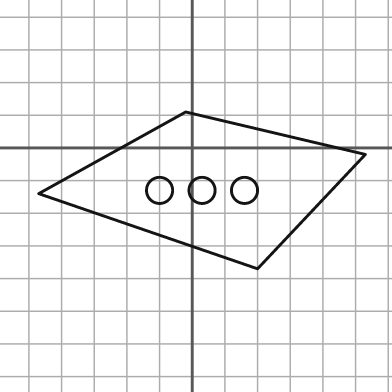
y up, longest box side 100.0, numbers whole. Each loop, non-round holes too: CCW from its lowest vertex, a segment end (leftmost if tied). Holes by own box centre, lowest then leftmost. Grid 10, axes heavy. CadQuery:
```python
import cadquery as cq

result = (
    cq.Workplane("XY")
    .moveTo(20.0, -37.0)
    .lineTo(53.0, -2.0)
    .lineTo(-2.0, 11.0)
    .lineTo(-47.0, -14.0)
    .close()
    .moveTo(-10.0, -13.0)
    .circle(4.0)
    .moveTo(3.0, -13.0)
    .circle(4.0)
    .moveTo(16.0, -13.0)
    .circle(4.0)
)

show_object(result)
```